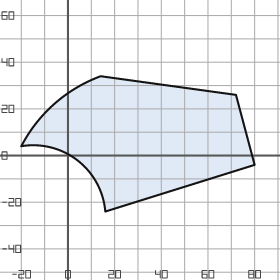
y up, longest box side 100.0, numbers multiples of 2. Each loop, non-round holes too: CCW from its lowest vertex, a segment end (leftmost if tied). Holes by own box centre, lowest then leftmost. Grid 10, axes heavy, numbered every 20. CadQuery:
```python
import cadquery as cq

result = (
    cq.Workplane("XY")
    .moveTo(16.0, -24.0)
    .lineTo(80.0, -4.0)
    .lineTo(72.0, 26.0)
    .lineTo(14.0, 34.0)
    .threePointArc((-6.0, 22.0), (-20.0, 4.0))
    .threePointArc((4.0, -2.0), (16.0, -24.0))
    .close()
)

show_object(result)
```